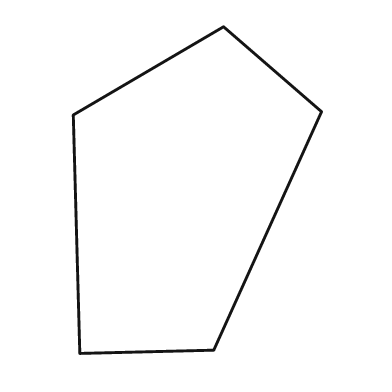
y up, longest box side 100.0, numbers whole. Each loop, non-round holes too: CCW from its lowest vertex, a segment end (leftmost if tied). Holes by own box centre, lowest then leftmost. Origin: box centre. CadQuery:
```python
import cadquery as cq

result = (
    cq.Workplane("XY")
    .moveTo(-36.0, -50.0)
    .lineTo(5.0, -49.0)
    .lineTo(38.0, 24.0)
    .lineTo(8.0, 50.0)
    .lineTo(-38.0, 23.0)
    .close()
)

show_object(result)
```